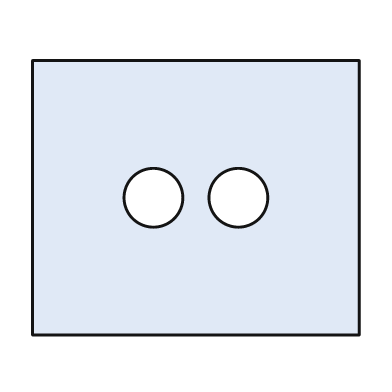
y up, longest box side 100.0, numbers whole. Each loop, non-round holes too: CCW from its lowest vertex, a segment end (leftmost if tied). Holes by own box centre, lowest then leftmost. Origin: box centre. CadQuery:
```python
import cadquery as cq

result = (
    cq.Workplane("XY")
    .moveTo(-50.0, -42.0)
    .lineTo(50.0, -42.0)
    .lineTo(50.0, 42.0)
    .lineTo(-50.0, 42.0)
    .close()
    .moveTo(-13.0, 0.0)
    .circle(9.0)
    .moveTo(13.0, 0.0)
    .circle(9.0)
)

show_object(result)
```